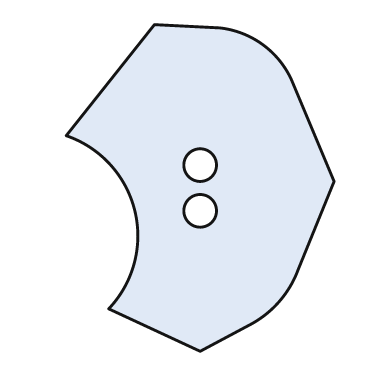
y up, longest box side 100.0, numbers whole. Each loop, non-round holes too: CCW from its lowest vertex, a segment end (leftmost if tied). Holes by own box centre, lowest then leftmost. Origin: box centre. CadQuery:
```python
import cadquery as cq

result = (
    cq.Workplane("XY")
    .moveTo(0.0, -50.0)
    .lineTo(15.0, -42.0)
    .threePointArc((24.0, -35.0), (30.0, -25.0))
    .lineTo(41.0, 2.0)
    .lineTo(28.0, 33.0)
    .threePointArc((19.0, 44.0), (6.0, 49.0))
    .lineTo(-14.0, 50.0)
    .lineTo(-41.0, 16.0)
    .threePointArc((-20.0, -7.0), (-28.0, -37.0))
    .close()
    .moveTo(0.0, -7.0)
    .circle(5.0)
    .moveTo(0.0, 7.0)
    .circle(5.0)
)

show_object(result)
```